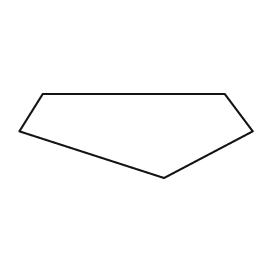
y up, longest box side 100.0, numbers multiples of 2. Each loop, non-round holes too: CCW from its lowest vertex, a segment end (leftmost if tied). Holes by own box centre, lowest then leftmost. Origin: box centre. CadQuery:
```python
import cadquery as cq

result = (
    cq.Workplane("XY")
    .moveTo(12.0, -18.0)
    .lineTo(50.0, 2.0)
    .lineTo(38.0, 18.0)
    .lineTo(-40.0, 18.0)
    .lineTo(-50.0, 2.0)
    .close()
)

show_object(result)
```